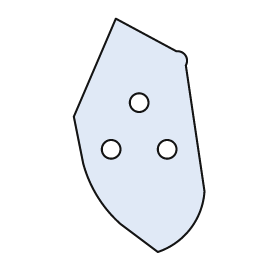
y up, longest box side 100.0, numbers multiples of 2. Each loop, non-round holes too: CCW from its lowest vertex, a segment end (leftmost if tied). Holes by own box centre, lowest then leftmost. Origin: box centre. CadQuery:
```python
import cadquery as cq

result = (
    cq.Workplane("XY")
    .moveTo(8.0, -50.0)
    .threePointArc((22.0, -40.0), (28.0, -24.0))
    .lineTo(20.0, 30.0)
    .threePointArc((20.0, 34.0), (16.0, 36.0))
    .lineTo(-10.0, 50.0)
    .lineTo(-28.0, 8.0)
    .lineTo(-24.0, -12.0)
    .threePointArc((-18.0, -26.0), (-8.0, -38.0))
    .close()
    .moveTo(-12.0, -6.0)
    .circle(4.0)
    .moveTo(12.0, -6.0)
    .circle(4.0)
    .moveTo(0.0, 14.0)
    .circle(4.0)
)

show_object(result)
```